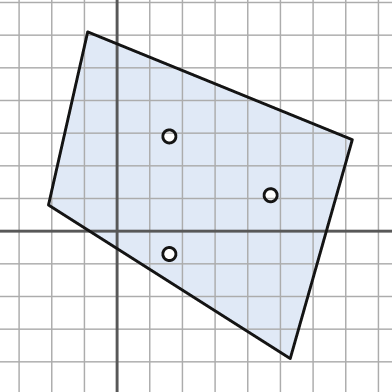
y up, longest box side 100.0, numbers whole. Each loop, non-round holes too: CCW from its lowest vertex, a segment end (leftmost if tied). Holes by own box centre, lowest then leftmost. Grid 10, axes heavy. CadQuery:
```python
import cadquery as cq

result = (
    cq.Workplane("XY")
    .moveTo(53.0, -39.0)
    .lineTo(72.0, 28.0)
    .lineTo(-9.0, 61.0)
    .lineTo(-21.0, 8.0)
    .close()
    .moveTo(16.0, -7.0)
    .circle(2.0)
    .moveTo(47.0, 11.0)
    .circle(2.0)
    .moveTo(16.0, 29.0)
    .circle(2.0)
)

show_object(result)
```